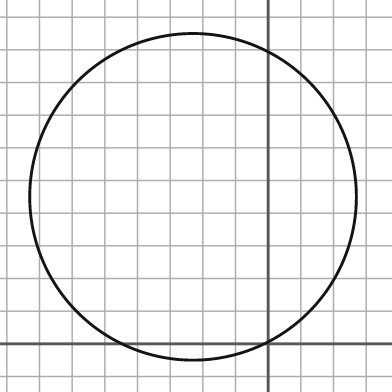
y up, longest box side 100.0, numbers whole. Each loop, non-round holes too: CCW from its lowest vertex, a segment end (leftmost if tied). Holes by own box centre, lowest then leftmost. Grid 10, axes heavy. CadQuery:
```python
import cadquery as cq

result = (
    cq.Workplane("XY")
    .moveTo(-23.0, 45.0)
    .circle(50.0)
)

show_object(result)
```